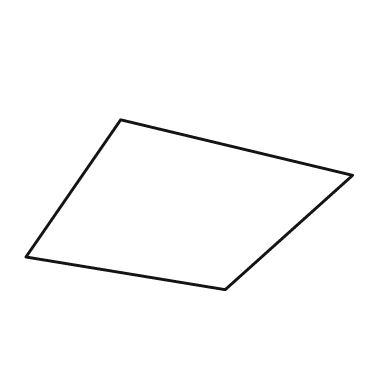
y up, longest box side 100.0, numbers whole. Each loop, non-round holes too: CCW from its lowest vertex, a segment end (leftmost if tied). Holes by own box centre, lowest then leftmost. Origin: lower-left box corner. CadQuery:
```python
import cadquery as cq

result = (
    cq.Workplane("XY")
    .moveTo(61.0, 0.0)
    .lineTo(100.0, 35.0)
    .lineTo(29.0, 52.0)
    .lineTo(0.0, 10.0)
    .close()
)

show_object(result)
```